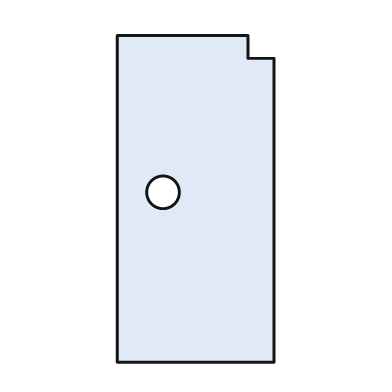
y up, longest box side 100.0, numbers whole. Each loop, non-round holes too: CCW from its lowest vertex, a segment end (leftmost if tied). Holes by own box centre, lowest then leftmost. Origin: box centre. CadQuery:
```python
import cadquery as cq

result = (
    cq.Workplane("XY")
    .moveTo(-24.0, -50.0)
    .lineTo(24.0, -50.0)
    .lineTo(24.0, 43.0)
    .lineTo(16.0, 43.0)
    .lineTo(16.0, 50.0)
    .lineTo(-24.0, 50.0)
    .close()
    .moveTo(-10.0, 2.0)
    .circle(5.0)
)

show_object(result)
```